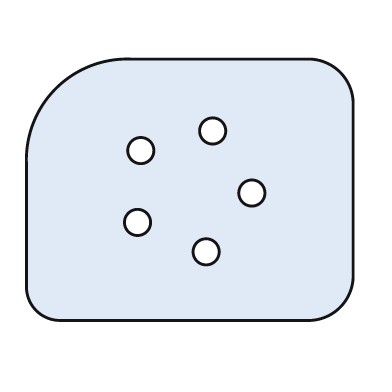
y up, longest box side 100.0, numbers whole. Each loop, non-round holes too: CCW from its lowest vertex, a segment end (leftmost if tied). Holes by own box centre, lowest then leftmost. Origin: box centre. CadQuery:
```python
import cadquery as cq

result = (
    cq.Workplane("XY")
    .moveTo(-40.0, -40.0)
    .lineTo(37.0, -40.0)
    .threePointArc((46.0, -36.0), (50.0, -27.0))
    .lineTo(50.0, 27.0)
    .threePointArc((46.0, 36.0), (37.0, 40.0))
    .lineTo(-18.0, 40.0)
    .threePointArc((-41.0, 31.0), (-50.0, 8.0))
    .lineTo(-50.0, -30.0)
    .threePointArc((-47.0, -37.0), (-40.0, -40.0))
    .close()
    .moveTo(5.0, -19.0)
    .circle(4.0)
    .moveTo(-16.0, -10.0)
    .circle(4.0)
    .moveTo(19.0, -1.0)
    .circle(4.0)
    .moveTo(-15.0, 12.0)
    .circle(4.0)
    .moveTo(7.0, 18.0)
    .circle(4.0)
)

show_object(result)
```